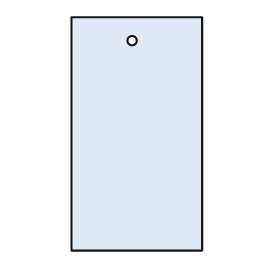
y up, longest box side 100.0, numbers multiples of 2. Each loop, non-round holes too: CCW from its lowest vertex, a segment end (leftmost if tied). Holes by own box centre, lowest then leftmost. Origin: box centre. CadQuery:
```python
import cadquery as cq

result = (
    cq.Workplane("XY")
    .moveTo(-28.0, -50.0)
    .lineTo(28.0, -50.0)
    .lineTo(28.0, 50.0)
    .lineTo(-28.0, 50.0)
    .close()
    .moveTo(-2.0, 40.0)
    .circle(2.0)
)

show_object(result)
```